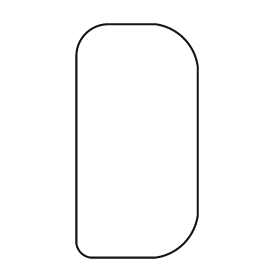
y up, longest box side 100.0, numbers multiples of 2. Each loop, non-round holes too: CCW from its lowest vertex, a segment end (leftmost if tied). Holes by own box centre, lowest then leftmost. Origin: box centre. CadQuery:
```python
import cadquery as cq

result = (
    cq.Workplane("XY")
    .moveTo(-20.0, -50.0)
    .lineTo(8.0, -50.0)
    .threePointArc((20.0, -44.0), (26.0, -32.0))
    .lineTo(26.0, 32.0)
    .threePointArc((20.0, 44.0), (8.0, 50.0))
    .lineTo(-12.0, 50.0)
    .threePointArc((-22.0, 46.0), (-26.0, 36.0))
    .lineTo(-26.0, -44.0)
    .threePointArc((-24.0, -48.0), (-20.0, -50.0))
    .close()
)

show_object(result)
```